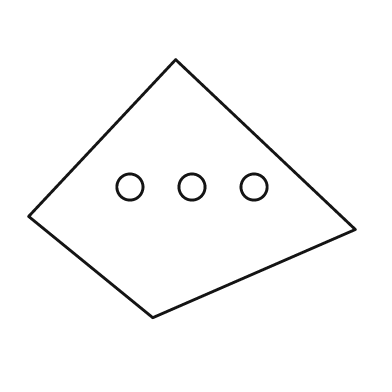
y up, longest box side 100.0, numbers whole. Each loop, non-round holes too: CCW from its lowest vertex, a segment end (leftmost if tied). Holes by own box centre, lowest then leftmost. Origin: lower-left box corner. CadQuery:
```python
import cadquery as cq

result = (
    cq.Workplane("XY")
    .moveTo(38.0, 0.0)
    .lineTo(100.0, 27.0)
    .lineTo(45.0, 79.0)
    .lineTo(0.0, 31.0)
    .close()
    .moveTo(31.0, 40.0)
    .circle(4.0)
    .moveTo(50.0, 40.0)
    .circle(4.0)
    .moveTo(69.0, 40.0)
    .circle(4.0)
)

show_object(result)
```